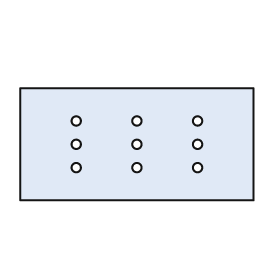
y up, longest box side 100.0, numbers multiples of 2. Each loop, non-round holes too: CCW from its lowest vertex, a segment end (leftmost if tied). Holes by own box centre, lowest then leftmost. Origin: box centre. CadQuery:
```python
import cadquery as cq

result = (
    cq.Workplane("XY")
    .moveTo(-50.0, -24.0)
    .lineTo(50.0, -24.0)
    .lineTo(50.0, 24.0)
    .lineTo(-50.0, 24.0)
    .close()
    .moveTo(-26.0, -10.0)
    .circle(2.0)
    .moveTo(0.0, -10.0)
    .circle(2.0)
    .moveTo(26.0, -10.0)
    .circle(2.0)
    .moveTo(-26.0, 0.0)
    .circle(2.0)
    .moveTo(0.0, 0.0)
    .circle(2.0)
    .moveTo(26.0, 0.0)
    .circle(2.0)
    .moveTo(-26.0, 10.0)
    .circle(2.0)
    .moveTo(0.0, 10.0)
    .circle(2.0)
    .moveTo(26.0, 10.0)
    .circle(2.0)
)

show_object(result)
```